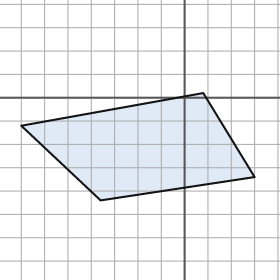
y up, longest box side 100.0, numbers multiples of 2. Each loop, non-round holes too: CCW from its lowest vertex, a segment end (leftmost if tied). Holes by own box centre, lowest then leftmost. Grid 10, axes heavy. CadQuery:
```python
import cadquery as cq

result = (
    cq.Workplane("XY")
    .moveTo(-36.0, -44.0)
    .lineTo(30.0, -34.0)
    .lineTo(8.0, 2.0)
    .lineTo(-70.0, -12.0)
    .close()
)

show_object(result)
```